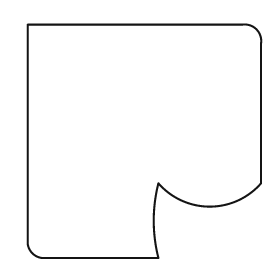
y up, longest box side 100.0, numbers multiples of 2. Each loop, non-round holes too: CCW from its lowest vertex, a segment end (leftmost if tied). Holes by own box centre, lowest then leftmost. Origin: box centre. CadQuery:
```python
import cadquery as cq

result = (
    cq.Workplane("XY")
    .moveTo(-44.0, -50.0)
    .lineTo(6.0, -50.0)
    .threePointArc((4.0, -34.0), (6.0, -18.0))
    .threePointArc((28.0, -28.0), (50.0, -18.0))
    .lineTo(50.0, 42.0)
    .threePointArc((48.0, 48.0), (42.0, 50.0))
    .lineTo(-50.0, 50.0)
    .lineTo(-50.0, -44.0)
    .threePointArc((-48.0, -48.0), (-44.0, -50.0))
    .close()
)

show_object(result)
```